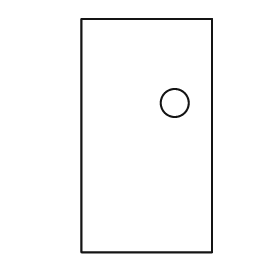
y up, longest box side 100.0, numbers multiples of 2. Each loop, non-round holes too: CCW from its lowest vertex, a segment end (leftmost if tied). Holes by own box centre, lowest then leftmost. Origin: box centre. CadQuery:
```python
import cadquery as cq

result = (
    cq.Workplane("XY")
    .moveTo(-28.0, -50.0)
    .lineTo(28.0, -50.0)
    .lineTo(28.0, 50.0)
    .lineTo(-28.0, 50.0)
    .close()
    .moveTo(12.0, 14.0)
    .circle(6.0)
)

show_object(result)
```